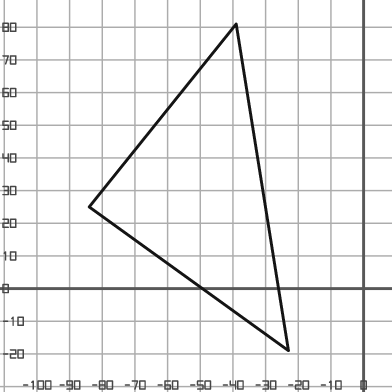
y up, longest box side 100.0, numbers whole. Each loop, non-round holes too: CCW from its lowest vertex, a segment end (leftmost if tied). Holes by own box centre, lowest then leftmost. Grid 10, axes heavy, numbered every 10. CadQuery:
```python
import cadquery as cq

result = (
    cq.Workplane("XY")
    .moveTo(-23.0, -19.0)
    .lineTo(-39.0, 81.0)
    .lineTo(-84.0, 25.0)
    .close()
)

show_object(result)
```